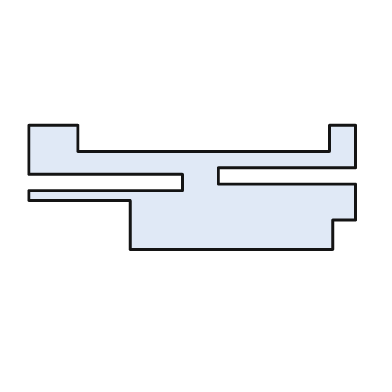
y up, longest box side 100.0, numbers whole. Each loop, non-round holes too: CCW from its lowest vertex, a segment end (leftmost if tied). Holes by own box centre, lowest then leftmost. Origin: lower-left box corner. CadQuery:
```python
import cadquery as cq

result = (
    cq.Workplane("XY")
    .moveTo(31.0, 0.0)
    .lineTo(93.0, 0.0)
    .lineTo(93.0, 9.0)
    .lineTo(100.0, 9.0)
    .lineTo(100.0, 20.0)
    .lineTo(58.0, 20.0)
    .lineTo(58.0, 25.0)
    .lineTo(100.0, 25.0)
    .lineTo(100.0, 38.0)
    .lineTo(92.0, 38.0)
    .lineTo(92.0, 30.0)
    .lineTo(15.0, 30.0)
    .lineTo(15.0, 38.0)
    .lineTo(0.0, 38.0)
    .lineTo(0.0, 23.0)
    .lineTo(47.0, 23.0)
    .lineTo(47.0, 18.0)
    .lineTo(0.0, 18.0)
    .lineTo(0.0, 15.0)
    .lineTo(31.0, 15.0)
    .close()
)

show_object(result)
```